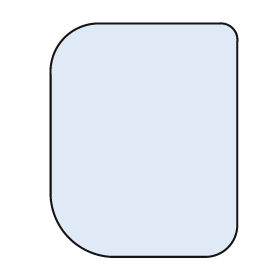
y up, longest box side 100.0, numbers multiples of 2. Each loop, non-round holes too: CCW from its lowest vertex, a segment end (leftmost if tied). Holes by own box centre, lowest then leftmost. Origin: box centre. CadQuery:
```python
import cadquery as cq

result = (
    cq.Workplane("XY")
    .moveTo(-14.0, -50.0)
    .lineTo(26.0, -50.0)
    .threePointArc((36.0, -46.0), (40.0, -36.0))
    .lineTo(40.0, 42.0)
    .threePointArc((38.0, 48.0), (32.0, 50.0))
    .lineTo(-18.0, 50.0)
    .threePointArc((-34.0, 44.0), (-40.0, 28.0))
    .lineTo(-40.0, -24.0)
    .threePointArc((-32.0, -42.0), (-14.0, -50.0))
    .close()
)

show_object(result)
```